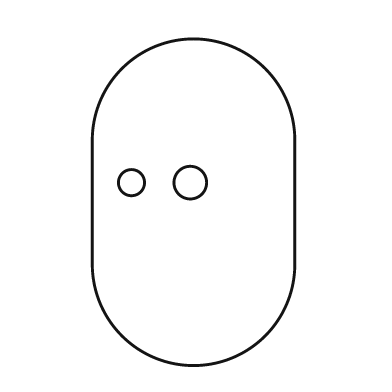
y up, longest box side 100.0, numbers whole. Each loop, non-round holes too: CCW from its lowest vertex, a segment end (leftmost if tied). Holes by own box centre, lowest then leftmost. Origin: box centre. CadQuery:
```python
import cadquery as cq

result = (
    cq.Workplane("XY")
    .moveTo(-31.0, -19.0)
    .threePointArc((0.0, -50.0), (31.0, -19.0))
    .lineTo(31.0, 19.0)
    .threePointArc((0.0, 50.0), (-31.0, 19.0))
    .close()
    .moveTo(-19.0, 6.0)
    .circle(4.0)
    .moveTo(-1.0, 6.0)
    .circle(5.0)
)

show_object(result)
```